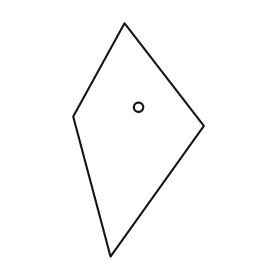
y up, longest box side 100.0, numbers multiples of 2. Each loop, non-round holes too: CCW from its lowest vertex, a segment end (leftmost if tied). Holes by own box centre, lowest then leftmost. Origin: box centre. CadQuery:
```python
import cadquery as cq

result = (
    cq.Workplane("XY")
    .moveTo(-12.0, -50.0)
    .lineTo(28.0, 6.0)
    .lineTo(-6.0, 50.0)
    .lineTo(-28.0, 10.0)
    .close()
    .moveTo(0.0, 14.0)
    .circle(2.0)
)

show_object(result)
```